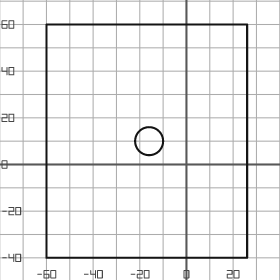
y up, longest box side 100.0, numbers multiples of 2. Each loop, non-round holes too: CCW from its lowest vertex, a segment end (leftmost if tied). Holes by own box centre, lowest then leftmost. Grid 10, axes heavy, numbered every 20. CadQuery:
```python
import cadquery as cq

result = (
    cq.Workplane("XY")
    .moveTo(-60.0, -40.0)
    .lineTo(26.0, -40.0)
    .lineTo(26.0, 60.0)
    .lineTo(-60.0, 60.0)
    .close()
    .moveTo(-16.0, 10.0)
    .circle(6.0)
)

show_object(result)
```